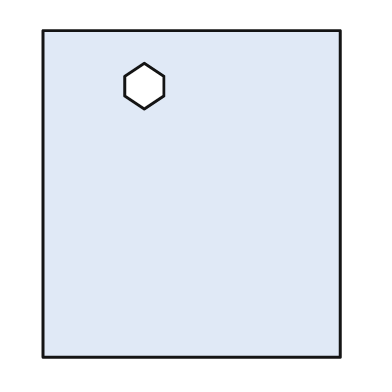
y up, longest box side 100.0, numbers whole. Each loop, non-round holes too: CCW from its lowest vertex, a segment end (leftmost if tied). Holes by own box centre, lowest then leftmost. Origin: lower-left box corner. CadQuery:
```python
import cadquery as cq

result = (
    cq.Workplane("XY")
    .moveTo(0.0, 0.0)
    .lineTo(91.0, 0.0)
    .lineTo(91.0, 100.0)
    .lineTo(0.0, 100.0)
    .close()
    .moveTo(31.0, 76.0)
    .lineTo(37.0, 80.0)
    .lineTo(37.0, 86.0)
    .lineTo(31.0, 90.0)
    .lineTo(25.0, 86.0)
    .lineTo(25.0, 80.0)
    .close()
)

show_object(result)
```